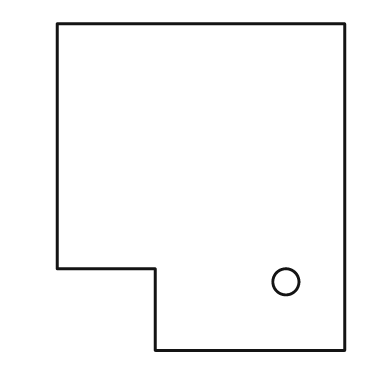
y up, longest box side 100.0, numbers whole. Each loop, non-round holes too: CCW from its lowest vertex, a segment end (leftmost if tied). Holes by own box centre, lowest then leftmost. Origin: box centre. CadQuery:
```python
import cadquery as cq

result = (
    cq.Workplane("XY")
    .moveTo(-14.0, -50.0)
    .lineTo(44.0, -50.0)
    .lineTo(44.0, 50.0)
    .lineTo(-44.0, 50.0)
    .lineTo(-44.0, -25.0)
    .lineTo(-14.0, -25.0)
    .close()
    .moveTo(26.0, -29.0)
    .circle(4.0)
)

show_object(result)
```